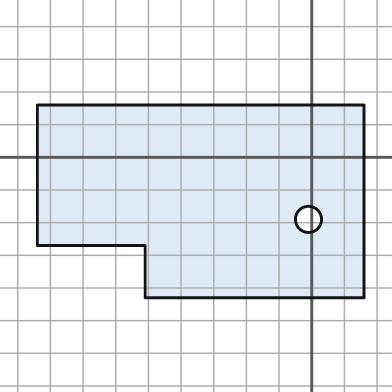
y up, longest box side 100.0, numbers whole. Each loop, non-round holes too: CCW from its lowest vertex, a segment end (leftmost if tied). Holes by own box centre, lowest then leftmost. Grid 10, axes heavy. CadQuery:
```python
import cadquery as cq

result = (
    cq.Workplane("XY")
    .moveTo(-51.0, -43.0)
    .lineTo(16.0, -43.0)
    .lineTo(16.0, 16.0)
    .lineTo(-84.0, 16.0)
    .lineTo(-84.0, -27.0)
    .lineTo(-51.0, -27.0)
    .close()
    .moveTo(-1.0, -19.0)
    .circle(4.0)
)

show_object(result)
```